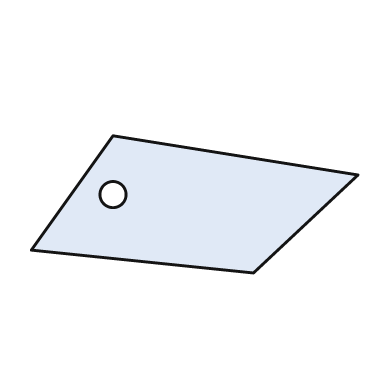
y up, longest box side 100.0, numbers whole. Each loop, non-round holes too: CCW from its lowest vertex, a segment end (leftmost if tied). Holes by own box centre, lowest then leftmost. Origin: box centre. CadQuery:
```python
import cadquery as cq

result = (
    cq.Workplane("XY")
    .moveTo(18.0, -21.0)
    .lineTo(50.0, 9.0)
    .lineTo(-25.0, 21.0)
    .lineTo(-50.0, -14.0)
    .close()
    .moveTo(-25.0, 3.0)
    .circle(4.0)
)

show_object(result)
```